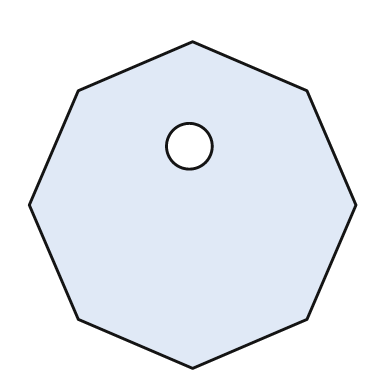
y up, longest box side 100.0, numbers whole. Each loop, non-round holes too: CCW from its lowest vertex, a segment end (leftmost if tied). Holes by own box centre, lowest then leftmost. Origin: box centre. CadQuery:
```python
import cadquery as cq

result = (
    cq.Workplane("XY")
    .moveTo(0.0, -50.0)
    .lineTo(35.0, -35.0)
    .lineTo(50.0, 0.0)
    .lineTo(35.0, 35.0)
    .lineTo(0.0, 50.0)
    .lineTo(-35.0, 35.0)
    .lineTo(-50.0, 0.0)
    .lineTo(-35.0, -35.0)
    .close()
    .moveTo(-1.0, 18.0)
    .circle(7.0)
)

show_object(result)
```